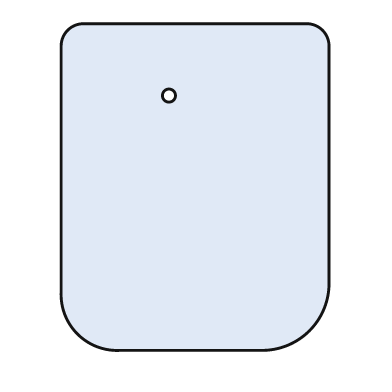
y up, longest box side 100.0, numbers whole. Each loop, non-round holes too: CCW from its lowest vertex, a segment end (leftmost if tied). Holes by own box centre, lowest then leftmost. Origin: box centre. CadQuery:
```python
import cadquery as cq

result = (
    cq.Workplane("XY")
    .moveTo(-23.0, -50.0)
    .lineTo(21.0, -50.0)
    .threePointArc((35.0, -44.0), (41.0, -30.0))
    .lineTo(41.0, 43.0)
    .threePointArc((39.0, 48.0), (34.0, 50.0))
    .lineTo(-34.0, 50.0)
    .threePointArc((-39.0, 48.0), (-41.0, 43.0))
    .lineTo(-41.0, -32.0)
    .threePointArc((-36.0, -45.0), (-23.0, -50.0))
    .close()
    .moveTo(-8.0, 28.0)
    .circle(2.0)
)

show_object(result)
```